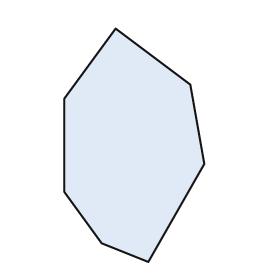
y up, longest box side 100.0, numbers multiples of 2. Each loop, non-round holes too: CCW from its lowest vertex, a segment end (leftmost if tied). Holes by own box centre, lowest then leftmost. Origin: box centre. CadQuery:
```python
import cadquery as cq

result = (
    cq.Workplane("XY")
    .moveTo(6.0, -50.0)
    .lineTo(30.0, -8.0)
    .lineTo(24.0, 26.0)
    .lineTo(-8.0, 50.0)
    .lineTo(-30.0, 20.0)
    .lineTo(-30.0, -20.0)
    .lineTo(-14.0, -42.0)
    .close()
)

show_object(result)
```